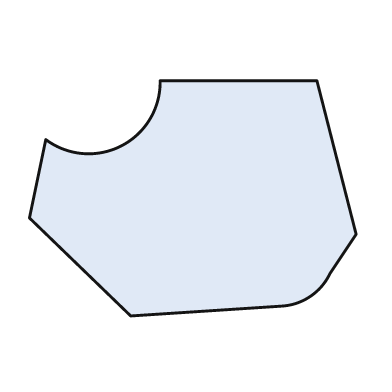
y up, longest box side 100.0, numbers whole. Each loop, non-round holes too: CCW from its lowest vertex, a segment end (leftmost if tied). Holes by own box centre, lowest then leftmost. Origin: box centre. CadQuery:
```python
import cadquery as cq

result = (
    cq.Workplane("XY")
    .moveTo(-19.0, -36.0)
    .lineTo(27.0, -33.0)
    .threePointArc((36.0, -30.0), (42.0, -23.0))
    .lineTo(50.0, -11.0)
    .lineTo(38.0, 36.0)
    .lineTo(-10.0, 36.0)
    .threePointArc((-22.0, 16.0), (-45.0, 18.0))
    .lineTo(-50.0, -6.0)
    .close()
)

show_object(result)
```